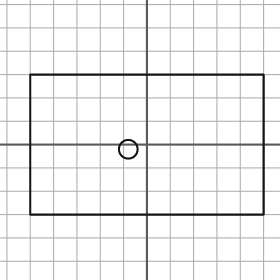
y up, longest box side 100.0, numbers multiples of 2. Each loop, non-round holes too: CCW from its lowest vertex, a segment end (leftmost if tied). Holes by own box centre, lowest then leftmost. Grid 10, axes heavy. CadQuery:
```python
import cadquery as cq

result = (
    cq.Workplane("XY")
    .moveTo(-50.0, -30.0)
    .lineTo(50.0, -30.0)
    .lineTo(50.0, 30.0)
    .lineTo(-50.0, 30.0)
    .close()
    .moveTo(-8.0, -2.0)
    .circle(4.0)
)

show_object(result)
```